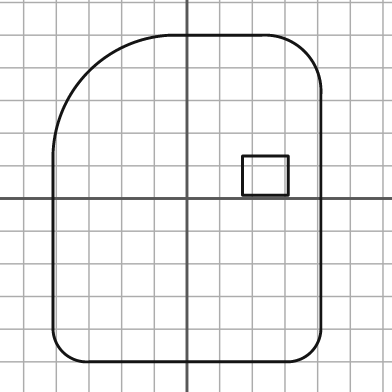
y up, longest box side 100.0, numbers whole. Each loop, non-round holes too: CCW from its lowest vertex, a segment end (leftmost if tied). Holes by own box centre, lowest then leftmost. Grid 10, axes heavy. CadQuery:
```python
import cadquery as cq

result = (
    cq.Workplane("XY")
    .moveTo(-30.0, -50.0)
    .lineTo(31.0, -50.0)
    .threePointArc((38.0, -47.0), (41.0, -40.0))
    .lineTo(41.0, 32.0)
    .threePointArc((36.0, 45.0), (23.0, 50.0))
    .lineTo(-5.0, 50.0)
    .threePointArc((-30.0, 39.0), (-41.0, 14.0))
    .lineTo(-41.0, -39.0)
    .threePointArc((-38.0, -47.0), (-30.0, -50.0))
    .close()
    .moveTo(17.0, 1.0)
    .lineTo(31.0, 1.0)
    .lineTo(31.0, 13.0)
    .lineTo(17.0, 13.0)
    .close()
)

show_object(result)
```